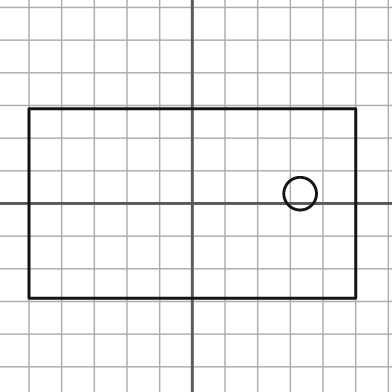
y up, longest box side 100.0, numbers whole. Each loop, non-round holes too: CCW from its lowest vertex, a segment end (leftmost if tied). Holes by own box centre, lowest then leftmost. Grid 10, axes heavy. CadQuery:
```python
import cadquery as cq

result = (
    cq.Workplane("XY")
    .moveTo(-50.0, -29.0)
    .lineTo(50.0, -29.0)
    .lineTo(50.0, 29.0)
    .lineTo(-50.0, 29.0)
    .close()
    .moveTo(33.0, 3.0)
    .circle(5.0)
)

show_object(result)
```